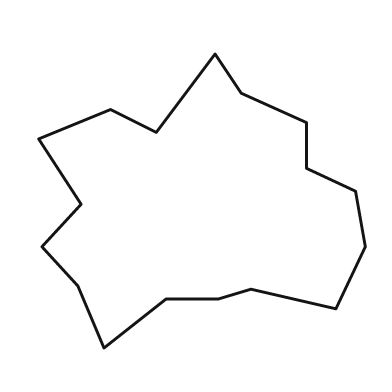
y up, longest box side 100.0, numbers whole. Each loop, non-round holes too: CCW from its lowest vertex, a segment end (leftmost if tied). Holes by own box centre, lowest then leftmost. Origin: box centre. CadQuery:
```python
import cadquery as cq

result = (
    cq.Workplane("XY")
    .moveTo(-30.0, -45.0)
    .lineTo(-11.0, -30.0)
    .lineTo(5.0, -30.0)
    .lineTo(15.0, -27.0)
    .lineTo(41.0, -33.0)
    .lineTo(50.0, -14.0)
    .lineTo(47.0, 3.0)
    .lineTo(32.0, 10.0)
    .lineTo(32.0, 24.0)
    .lineTo(12.0, 33.0)
    .lineTo(4.0, 45.0)
    .lineTo(-14.0, 21.0)
    .lineTo(-28.0, 28.0)
    .lineTo(-50.0, 19.0)
    .lineTo(-37.0, -1.0)
    .lineTo(-49.0, -14.0)
    .lineTo(-38.0, -26.0)
    .close()
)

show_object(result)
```